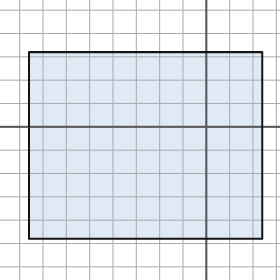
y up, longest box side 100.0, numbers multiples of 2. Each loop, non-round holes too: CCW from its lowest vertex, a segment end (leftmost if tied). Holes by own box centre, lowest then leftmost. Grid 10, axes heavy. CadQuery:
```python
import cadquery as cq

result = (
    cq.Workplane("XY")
    .moveTo(-76.0, -48.0)
    .lineTo(24.0, -48.0)
    .lineTo(24.0, 32.0)
    .lineTo(-76.0, 32.0)
    .close()
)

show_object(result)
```